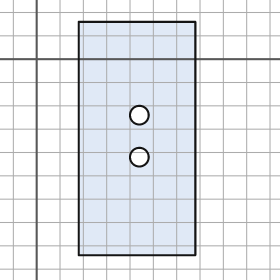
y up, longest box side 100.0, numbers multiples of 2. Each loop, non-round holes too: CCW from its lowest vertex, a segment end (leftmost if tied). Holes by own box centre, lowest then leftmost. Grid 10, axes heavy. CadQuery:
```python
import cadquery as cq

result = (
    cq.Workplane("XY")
    .moveTo(18.0, -84.0)
    .lineTo(68.0, -84.0)
    .lineTo(68.0, 16.0)
    .lineTo(18.0, 16.0)
    .close()
    .moveTo(44.0, -42.0)
    .circle(4.0)
    .moveTo(44.0, -24.0)
    .circle(4.0)
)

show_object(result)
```